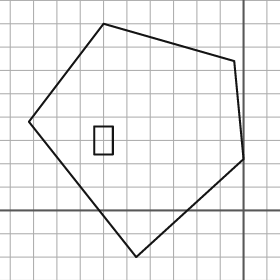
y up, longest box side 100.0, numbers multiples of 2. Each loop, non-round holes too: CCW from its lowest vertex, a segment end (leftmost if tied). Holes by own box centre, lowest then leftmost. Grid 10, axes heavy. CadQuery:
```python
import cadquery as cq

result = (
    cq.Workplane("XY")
    .moveTo(-46.0, -20.0)
    .lineTo(0.0, 22.0)
    .lineTo(-4.0, 64.0)
    .lineTo(-60.0, 80.0)
    .lineTo(-92.0, 38.0)
    .close()
    .moveTo(-64.0, 24.0)
    .lineTo(-56.0, 24.0)
    .lineTo(-56.0, 36.0)
    .lineTo(-64.0, 36.0)
    .close()
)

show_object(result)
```